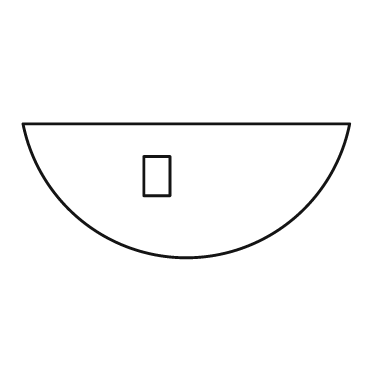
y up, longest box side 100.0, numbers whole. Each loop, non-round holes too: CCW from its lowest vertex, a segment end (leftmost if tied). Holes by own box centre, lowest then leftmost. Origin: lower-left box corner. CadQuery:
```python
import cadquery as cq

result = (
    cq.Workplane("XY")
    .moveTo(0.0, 41.0)
    .threePointArc((50.0, 0.0), (100.0, 41.0))
    .close()
    .moveTo(37.0, 19.0)
    .lineTo(45.0, 19.0)
    .lineTo(45.0, 31.0)
    .lineTo(37.0, 31.0)
    .close()
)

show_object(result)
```